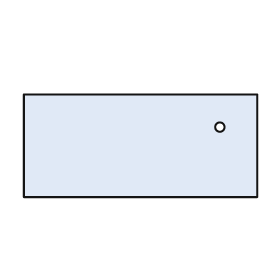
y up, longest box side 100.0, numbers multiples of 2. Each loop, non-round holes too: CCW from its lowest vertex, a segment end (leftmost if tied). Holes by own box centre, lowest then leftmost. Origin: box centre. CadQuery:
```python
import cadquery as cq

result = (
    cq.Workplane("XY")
    .moveTo(-50.0, -22.0)
    .lineTo(50.0, -22.0)
    .lineTo(50.0, 22.0)
    .lineTo(-50.0, 22.0)
    .close()
    .moveTo(34.0, 8.0)
    .circle(2.0)
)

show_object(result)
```